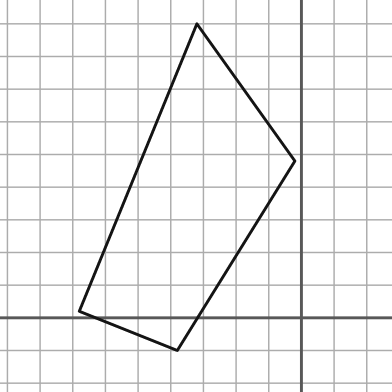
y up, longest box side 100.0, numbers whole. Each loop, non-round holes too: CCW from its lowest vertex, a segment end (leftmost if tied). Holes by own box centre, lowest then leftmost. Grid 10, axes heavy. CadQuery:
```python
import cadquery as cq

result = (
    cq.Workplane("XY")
    .moveTo(-38.0, -10.0)
    .lineTo(-2.0, 48.0)
    .lineTo(-32.0, 90.0)
    .lineTo(-68.0, 2.0)
    .close()
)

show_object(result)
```